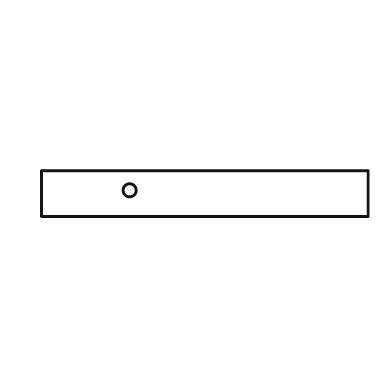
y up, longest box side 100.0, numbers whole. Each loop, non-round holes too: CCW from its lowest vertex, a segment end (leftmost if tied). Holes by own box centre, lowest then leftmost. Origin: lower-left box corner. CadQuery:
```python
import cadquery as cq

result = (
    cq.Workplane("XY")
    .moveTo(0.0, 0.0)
    .lineTo(100.0, 0.0)
    .lineTo(100.0, 14.0)
    .lineTo(0.0, 14.0)
    .close()
    .moveTo(27.0, 8.0)
    .circle(2.0)
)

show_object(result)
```